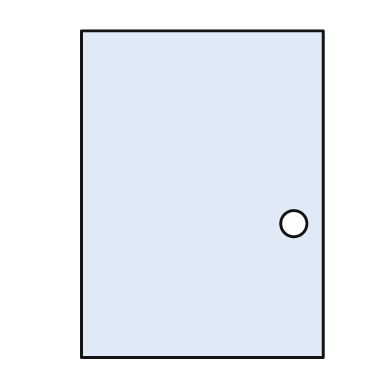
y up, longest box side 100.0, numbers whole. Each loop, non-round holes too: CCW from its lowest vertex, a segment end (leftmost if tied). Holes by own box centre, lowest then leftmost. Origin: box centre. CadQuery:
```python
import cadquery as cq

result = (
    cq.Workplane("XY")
    .moveTo(-37.0, -50.0)
    .lineTo(37.0, -50.0)
    .lineTo(37.0, 50.0)
    .lineTo(-37.0, 50.0)
    .close()
    .moveTo(28.0, -9.0)
    .circle(4.0)
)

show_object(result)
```